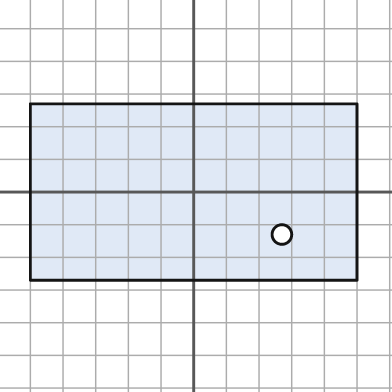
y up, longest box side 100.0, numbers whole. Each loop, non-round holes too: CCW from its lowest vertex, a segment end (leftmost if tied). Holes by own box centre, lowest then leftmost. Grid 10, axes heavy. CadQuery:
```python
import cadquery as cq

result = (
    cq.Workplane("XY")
    .moveTo(-50.0, -27.0)
    .lineTo(50.0, -27.0)
    .lineTo(50.0, 27.0)
    .lineTo(-50.0, 27.0)
    .close()
    .moveTo(27.0, -13.0)
    .circle(3.0)
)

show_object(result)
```